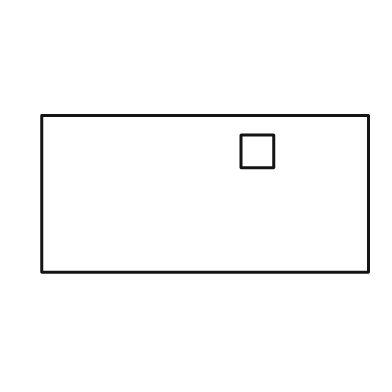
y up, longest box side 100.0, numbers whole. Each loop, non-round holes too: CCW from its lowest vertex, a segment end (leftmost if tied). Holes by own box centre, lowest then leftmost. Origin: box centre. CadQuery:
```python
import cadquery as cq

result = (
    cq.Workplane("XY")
    .moveTo(-50.0, -24.0)
    .lineTo(50.0, -24.0)
    .lineTo(50.0, 24.0)
    .lineTo(-50.0, 24.0)
    .close()
    .moveTo(11.0, 8.0)
    .lineTo(21.0, 8.0)
    .lineTo(21.0, 18.0)
    .lineTo(11.0, 18.0)
    .close()
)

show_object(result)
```